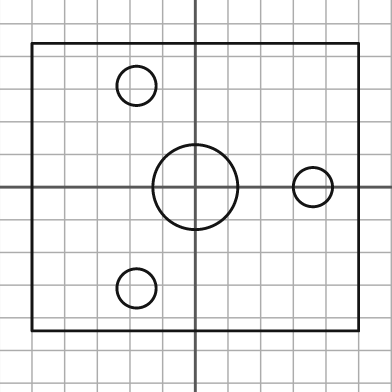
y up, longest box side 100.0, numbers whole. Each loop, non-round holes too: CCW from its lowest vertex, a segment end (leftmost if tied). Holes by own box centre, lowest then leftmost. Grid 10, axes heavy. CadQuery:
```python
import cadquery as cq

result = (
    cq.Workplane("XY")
    .moveTo(-50.0, -44.0)
    .lineTo(50.0, -44.0)
    .lineTo(50.0, 44.0)
    .lineTo(-50.0, 44.0)
    .close()
    .moveTo(-18.0, -31.0)
    .circle(6.0)
    .moveTo(0.0, 0.0)
    .circle(13.0)
    .moveTo(36.0, 0.0)
    .circle(6.0)
    .moveTo(-18.0, 31.0)
    .circle(6.0)
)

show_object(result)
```